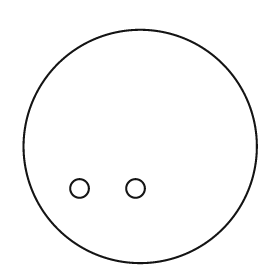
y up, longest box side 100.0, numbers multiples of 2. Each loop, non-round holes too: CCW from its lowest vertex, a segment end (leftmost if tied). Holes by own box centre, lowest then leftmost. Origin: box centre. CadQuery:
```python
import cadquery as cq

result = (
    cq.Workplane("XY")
    .moveTo(0.0, 0.0)
    .circle(50.0)
    .moveTo(-26.0, -18.0)
    .circle(4.0)
    .moveTo(-2.0, -18.0)
    .circle(4.0)
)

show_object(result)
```